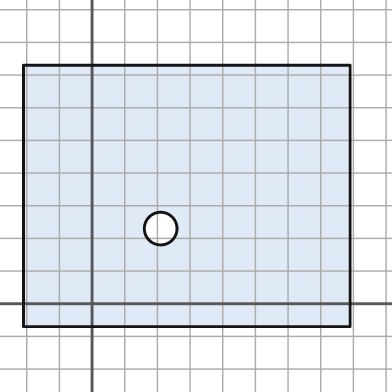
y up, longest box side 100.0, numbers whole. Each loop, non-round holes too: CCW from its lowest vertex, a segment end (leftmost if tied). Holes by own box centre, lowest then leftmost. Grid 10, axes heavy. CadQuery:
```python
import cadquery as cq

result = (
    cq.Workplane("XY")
    .moveTo(-21.0, -7.0)
    .lineTo(79.0, -7.0)
    .lineTo(79.0, 73.0)
    .lineTo(-21.0, 73.0)
    .close()
    .moveTo(21.0, 23.0)
    .circle(5.0)
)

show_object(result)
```